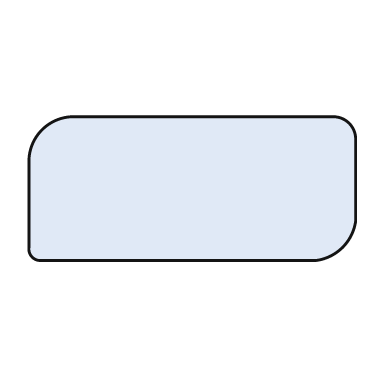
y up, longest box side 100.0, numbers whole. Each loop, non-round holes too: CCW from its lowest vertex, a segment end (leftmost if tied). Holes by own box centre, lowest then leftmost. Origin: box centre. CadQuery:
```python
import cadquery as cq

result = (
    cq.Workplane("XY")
    .moveTo(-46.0, -22.0)
    .lineTo(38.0, -22.0)
    .threePointArc((46.0, -18.0), (50.0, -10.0))
    .lineTo(50.0, 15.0)
    .threePointArc((48.0, 20.0), (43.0, 22.0))
    .lineTo(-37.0, 22.0)
    .threePointArc((-46.0, 18.0), (-50.0, 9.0))
    .lineTo(-50.0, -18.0)
    .threePointArc((-49.0, -21.0), (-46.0, -22.0))
    .close()
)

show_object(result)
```